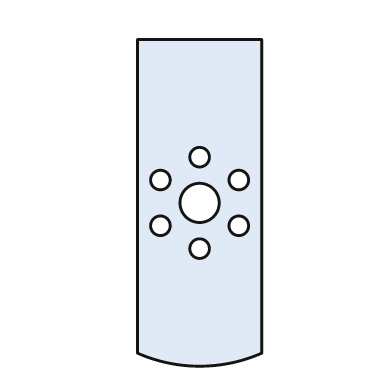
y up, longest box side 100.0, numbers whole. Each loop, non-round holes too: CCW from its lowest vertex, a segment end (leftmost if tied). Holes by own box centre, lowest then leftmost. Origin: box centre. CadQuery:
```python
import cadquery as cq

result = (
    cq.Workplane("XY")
    .moveTo(-19.0, -46.0)
    .threePointArc((0.0, -50.0), (19.0, -46.0))
    .lineTo(19.0, 50.0)
    .lineTo(-19.0, 50.0)
    .close()
    .moveTo(0.0, -14.0)
    .circle(3.0)
    .moveTo(-12.0, -7.0)
    .circle(3.0)
    .moveTo(12.0, -7.0)
    .circle(3.0)
    .moveTo(0.0, 0.0)
    .circle(6.0)
    .moveTo(-12.0, 7.0)
    .circle(3.0)
    .moveTo(12.0, 7.0)
    .circle(3.0)
    .moveTo(0.0, 14.0)
    .circle(3.0)
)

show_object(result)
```